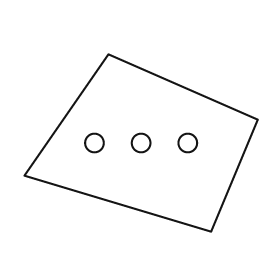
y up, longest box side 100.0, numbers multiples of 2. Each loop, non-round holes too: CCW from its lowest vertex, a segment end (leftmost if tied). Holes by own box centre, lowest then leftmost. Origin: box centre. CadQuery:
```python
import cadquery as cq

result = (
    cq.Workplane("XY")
    .moveTo(30.0, -38.0)
    .lineTo(50.0, 10.0)
    .lineTo(-14.0, 38.0)
    .lineTo(-50.0, -14.0)
    .close()
    .moveTo(-20.0, 0.0)
    .circle(4.0)
    .moveTo(0.0, 0.0)
    .circle(4.0)
    .moveTo(20.0, 0.0)
    .circle(4.0)
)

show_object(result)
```